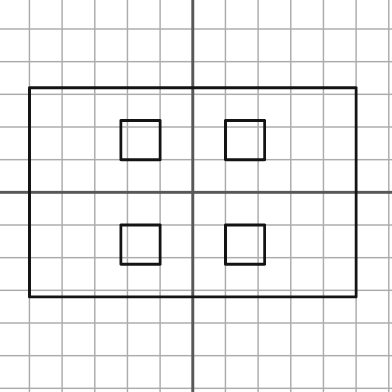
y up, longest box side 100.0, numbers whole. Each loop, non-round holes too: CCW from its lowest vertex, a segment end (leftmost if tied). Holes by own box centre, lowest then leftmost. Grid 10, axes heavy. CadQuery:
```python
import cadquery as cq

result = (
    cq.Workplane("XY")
    .moveTo(-50.0, -32.0)
    .lineTo(50.0, -32.0)
    .lineTo(50.0, 32.0)
    .lineTo(-50.0, 32.0)
    .close()
    .moveTo(-22.0, -22.0)
    .lineTo(-10.0, -22.0)
    .lineTo(-10.0, -10.0)
    .lineTo(-22.0, -10.0)
    .close()
    .moveTo(10.0, -22.0)
    .lineTo(22.0, -22.0)
    .lineTo(22.0, -10.0)
    .lineTo(10.0, -10.0)
    .close()
    .moveTo(-22.0, 10.0)
    .lineTo(-10.0, 10.0)
    .lineTo(-10.0, 22.0)
    .lineTo(-22.0, 22.0)
    .close()
    .moveTo(10.0, 10.0)
    .lineTo(22.0, 10.0)
    .lineTo(22.0, 22.0)
    .lineTo(10.0, 22.0)
    .close()
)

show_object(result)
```